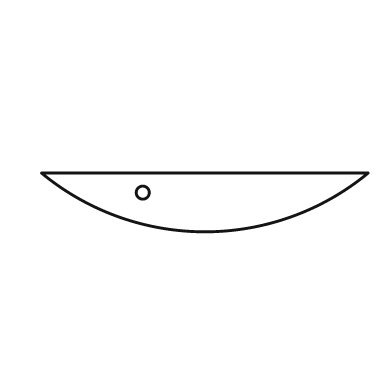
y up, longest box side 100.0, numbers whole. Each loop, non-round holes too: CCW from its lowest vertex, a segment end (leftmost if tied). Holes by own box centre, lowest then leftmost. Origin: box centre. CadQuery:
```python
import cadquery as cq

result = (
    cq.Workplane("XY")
    .moveTo(-50.0, 9.0)
    .threePointArc((0.0, -9.0), (50.0, 9.0))
    .close()
    .moveTo(-19.0, 3.0)
    .circle(2.0)
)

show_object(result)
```